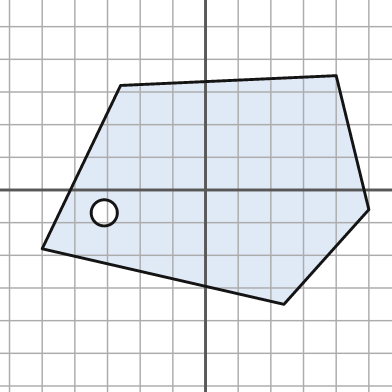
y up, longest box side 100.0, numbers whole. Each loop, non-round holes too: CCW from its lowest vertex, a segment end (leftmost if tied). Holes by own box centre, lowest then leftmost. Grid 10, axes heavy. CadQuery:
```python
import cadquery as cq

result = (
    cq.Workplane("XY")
    .moveTo(24.0, -35.0)
    .lineTo(50.0, -6.0)
    .lineTo(40.0, 35.0)
    .lineTo(-26.0, 32.0)
    .lineTo(-50.0, -18.0)
    .close()
    .moveTo(-31.0, -7.0)
    .circle(4.0)
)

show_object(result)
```